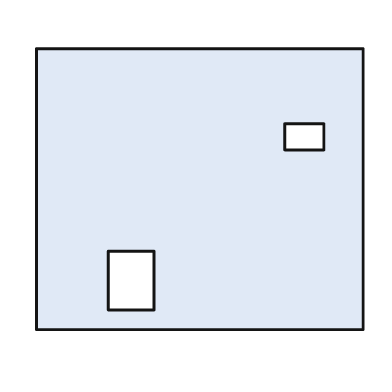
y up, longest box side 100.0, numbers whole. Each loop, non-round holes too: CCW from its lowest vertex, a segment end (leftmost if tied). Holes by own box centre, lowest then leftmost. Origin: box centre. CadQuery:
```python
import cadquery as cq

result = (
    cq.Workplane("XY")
    .moveTo(-50.0, -43.0)
    .lineTo(50.0, -43.0)
    .lineTo(50.0, 43.0)
    .lineTo(-50.0, 43.0)
    .close()
    .moveTo(-28.0, -37.0)
    .lineTo(-14.0, -37.0)
    .lineTo(-14.0, -19.0)
    .lineTo(-28.0, -19.0)
    .close()
    .moveTo(26.0, 12.0)
    .lineTo(38.0, 12.0)
    .lineTo(38.0, 20.0)
    .lineTo(26.0, 20.0)
    .close()
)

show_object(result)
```